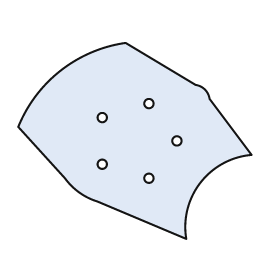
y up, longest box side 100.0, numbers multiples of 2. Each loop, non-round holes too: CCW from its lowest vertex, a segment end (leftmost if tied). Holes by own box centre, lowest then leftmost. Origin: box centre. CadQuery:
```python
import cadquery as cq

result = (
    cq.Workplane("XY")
    .moveTo(22.0, -42.0)
    .threePointArc((28.0, -18.0), (50.0, -6.0))
    .lineTo(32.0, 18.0)
    .threePointArc((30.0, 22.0), (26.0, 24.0))
    .lineTo(-4.0, 42.0)
    .threePointArc((-32.0, 30.0), (-50.0, 6.0))
    .lineTo(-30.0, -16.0)
    .threePointArc((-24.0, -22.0), (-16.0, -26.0))
    .close()
    .moveTo(6.0, -16.0)
    .circle(2.0)
    .moveTo(-14.0, -10.0)
    .circle(2.0)
    .moveTo(18.0, 0.0)
    .circle(2.0)
    .moveTo(-14.0, 10.0)
    .circle(2.0)
    .moveTo(6.0, 16.0)
    .circle(2.0)
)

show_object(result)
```